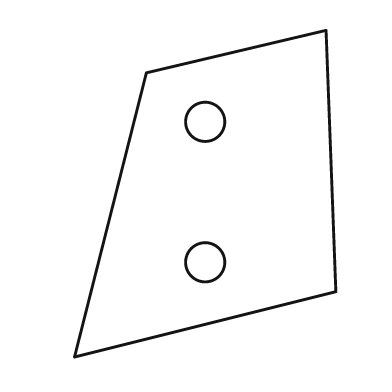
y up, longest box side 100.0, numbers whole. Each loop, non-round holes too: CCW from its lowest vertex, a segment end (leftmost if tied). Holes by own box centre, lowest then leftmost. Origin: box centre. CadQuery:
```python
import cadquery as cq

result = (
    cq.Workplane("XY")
    .moveTo(-40.0, -50.0)
    .lineTo(40.0, -30.0)
    .lineTo(37.0, 50.0)
    .lineTo(-18.0, 37.0)
    .close()
    .moveTo(0.0, -21.0)
    .circle(6.0)
    .moveTo(0.0, 22.0)
    .circle(6.0)
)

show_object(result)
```